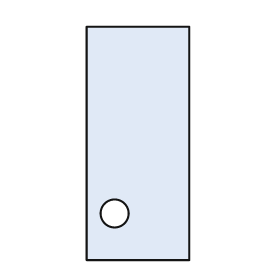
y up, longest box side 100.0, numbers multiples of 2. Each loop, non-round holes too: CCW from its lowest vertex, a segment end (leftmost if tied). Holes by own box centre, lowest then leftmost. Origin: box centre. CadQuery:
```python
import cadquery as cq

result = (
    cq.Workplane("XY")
    .moveTo(-22.0, -50.0)
    .lineTo(22.0, -50.0)
    .lineTo(22.0, 50.0)
    .lineTo(-22.0, 50.0)
    .close()
    .moveTo(-10.0, -30.0)
    .circle(6.0)
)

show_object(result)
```